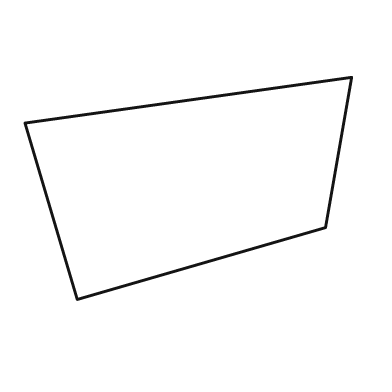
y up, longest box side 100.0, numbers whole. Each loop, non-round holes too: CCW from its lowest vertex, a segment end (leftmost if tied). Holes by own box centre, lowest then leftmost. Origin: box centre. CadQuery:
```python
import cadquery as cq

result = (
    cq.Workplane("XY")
    .moveTo(-34.0, -34.0)
    .lineTo(42.0, -12.0)
    .lineTo(50.0, 34.0)
    .lineTo(-50.0, 20.0)
    .close()
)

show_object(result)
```